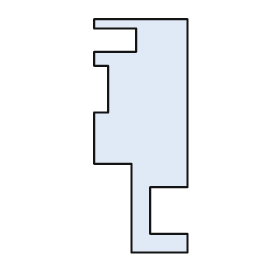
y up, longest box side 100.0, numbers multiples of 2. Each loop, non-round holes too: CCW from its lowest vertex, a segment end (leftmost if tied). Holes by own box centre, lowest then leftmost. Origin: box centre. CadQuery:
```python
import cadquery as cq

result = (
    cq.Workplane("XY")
    .moveTo(-4.0, -50.0)
    .lineTo(20.0, -50.0)
    .lineTo(20.0, -42.0)
    .lineTo(4.0, -42.0)
    .lineTo(4.0, -22.0)
    .lineTo(20.0, -22.0)
    .lineTo(20.0, 50.0)
    .lineTo(-20.0, 50.0)
    .lineTo(-20.0, 46.0)
    .lineTo(-2.0, 46.0)
    .lineTo(-2.0, 36.0)
    .lineTo(-20.0, 36.0)
    .lineTo(-20.0, 30.0)
    .lineTo(-14.0, 30.0)
    .lineTo(-14.0, 10.0)
    .lineTo(-20.0, 10.0)
    .lineTo(-20.0, -12.0)
    .lineTo(-4.0, -12.0)
    .close()
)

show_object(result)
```